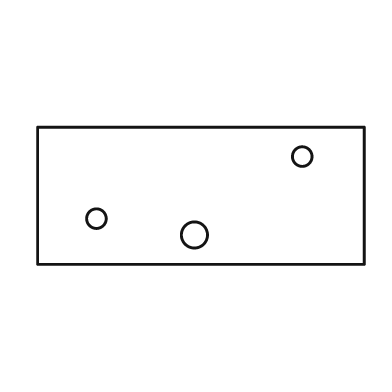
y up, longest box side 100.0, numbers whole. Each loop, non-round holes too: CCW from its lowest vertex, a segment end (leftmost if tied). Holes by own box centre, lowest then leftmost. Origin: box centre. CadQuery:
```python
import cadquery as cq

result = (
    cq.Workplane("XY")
    .moveTo(-50.0, -21.0)
    .lineTo(50.0, -21.0)
    .lineTo(50.0, 21.0)
    .lineTo(-50.0, 21.0)
    .close()
    .moveTo(-2.0, -12.0)
    .circle(4.0)
    .moveTo(-32.0, -7.0)
    .circle(3.0)
    .moveTo(31.0, 12.0)
    .circle(3.0)
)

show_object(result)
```